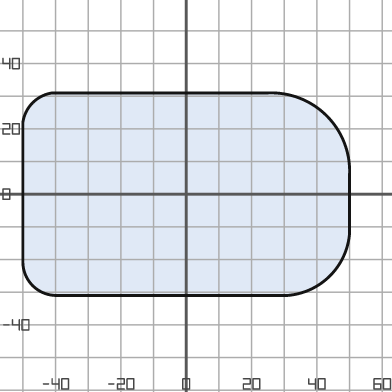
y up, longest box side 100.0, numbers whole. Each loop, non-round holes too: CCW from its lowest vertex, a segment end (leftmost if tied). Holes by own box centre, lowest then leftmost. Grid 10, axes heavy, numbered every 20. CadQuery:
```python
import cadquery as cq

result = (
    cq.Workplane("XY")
    .moveTo(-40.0, -31.0)
    .lineTo(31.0, -31.0)
    .threePointArc((44.0, -25.0), (50.0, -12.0))
    .lineTo(50.0, 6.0)
    .threePointArc((43.0, 24.0), (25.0, 31.0))
    .lineTo(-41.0, 31.0)
    .threePointArc((-47.0, 28.0), (-50.0, 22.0))
    .lineTo(-50.0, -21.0)
    .threePointArc((-47.0, -28.0), (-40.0, -31.0))
    .close()
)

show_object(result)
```